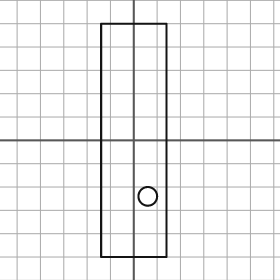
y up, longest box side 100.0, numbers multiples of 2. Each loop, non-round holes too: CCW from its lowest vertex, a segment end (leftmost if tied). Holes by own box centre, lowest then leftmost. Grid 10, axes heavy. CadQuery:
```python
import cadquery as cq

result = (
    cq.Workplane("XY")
    .moveTo(-14.0, -50.0)
    .lineTo(14.0, -50.0)
    .lineTo(14.0, 50.0)
    .lineTo(-14.0, 50.0)
    .close()
    .moveTo(6.0, -24.0)
    .circle(4.0)
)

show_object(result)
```